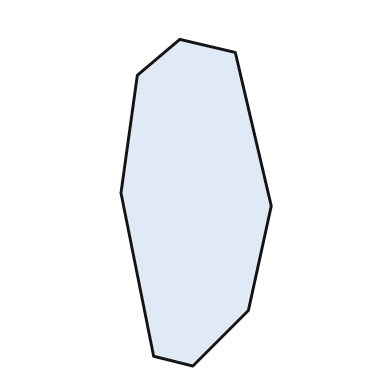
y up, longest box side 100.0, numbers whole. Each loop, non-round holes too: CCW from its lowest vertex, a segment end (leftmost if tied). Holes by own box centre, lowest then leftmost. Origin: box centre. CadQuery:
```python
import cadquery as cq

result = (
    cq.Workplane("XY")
    .moveTo(-1.0, -50.0)
    .lineTo(16.0, -33.0)
    .lineTo(23.0, -1.0)
    .lineTo(12.0, 46.0)
    .lineTo(-5.0, 50.0)
    .lineTo(-18.0, 39.0)
    .lineTo(-23.0, 3.0)
    .lineTo(-13.0, -47.0)
    .close()
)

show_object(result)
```